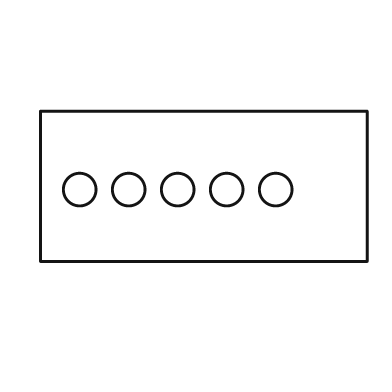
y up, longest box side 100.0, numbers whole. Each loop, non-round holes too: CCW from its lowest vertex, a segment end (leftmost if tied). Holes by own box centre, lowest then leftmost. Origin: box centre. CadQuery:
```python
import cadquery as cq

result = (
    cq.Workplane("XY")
    .moveTo(-50.0, -23.0)
    .lineTo(50.0, -23.0)
    .lineTo(50.0, 23.0)
    .lineTo(-50.0, 23.0)
    .close()
    .moveTo(-38.0, -1.0)
    .circle(5.0)
    .moveTo(-23.0, -1.0)
    .circle(5.0)
    .moveTo(-8.0, -1.0)
    .circle(5.0)
    .moveTo(7.0, -1.0)
    .circle(5.0)
    .moveTo(22.0, -1.0)
    .circle(5.0)
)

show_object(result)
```